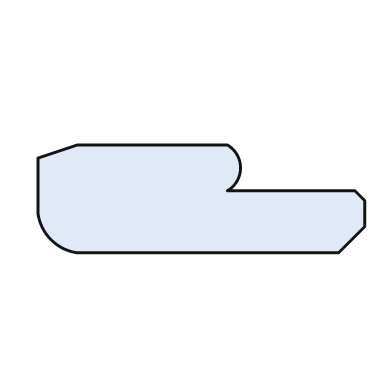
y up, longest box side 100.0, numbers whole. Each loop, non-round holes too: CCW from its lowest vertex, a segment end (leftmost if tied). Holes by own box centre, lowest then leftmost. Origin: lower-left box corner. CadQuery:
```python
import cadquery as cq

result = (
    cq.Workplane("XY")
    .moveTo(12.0, 0.0)
    .lineTo(92.0, 0.0)
    .lineTo(100.0, 8.0)
    .lineTo(100.0, 16.0)
    .lineTo(97.0, 19.0)
    .lineTo(58.0, 19.0)
    .threePointArc((62.0, 26.0), (58.0, 33.0))
    .lineTo(12.0, 33.0)
    .lineTo(0.0, 29.0)
    .lineTo(0.0, 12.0)
    .threePointArc((4.0, 4.0), (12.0, 0.0))
    .close()
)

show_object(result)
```